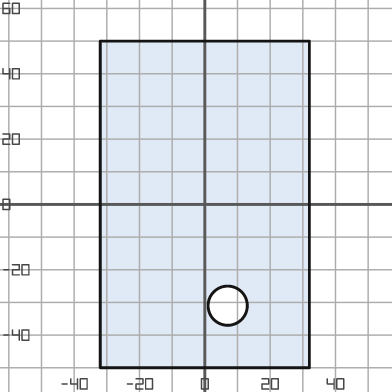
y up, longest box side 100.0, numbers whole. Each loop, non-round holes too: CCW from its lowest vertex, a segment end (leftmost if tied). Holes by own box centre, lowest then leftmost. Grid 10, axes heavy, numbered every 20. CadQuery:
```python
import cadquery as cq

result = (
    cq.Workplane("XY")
    .moveTo(-32.0, -50.0)
    .lineTo(32.0, -50.0)
    .lineTo(32.0, 50.0)
    .lineTo(-32.0, 50.0)
    .close()
    .moveTo(7.0, -31.0)
    .circle(6.0)
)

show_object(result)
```